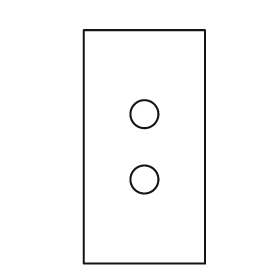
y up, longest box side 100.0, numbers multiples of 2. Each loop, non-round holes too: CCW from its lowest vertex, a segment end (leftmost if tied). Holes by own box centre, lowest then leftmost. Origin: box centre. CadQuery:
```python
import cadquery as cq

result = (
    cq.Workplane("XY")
    .moveTo(-26.0, -50.0)
    .lineTo(26.0, -50.0)
    .lineTo(26.0, 50.0)
    .lineTo(-26.0, 50.0)
    .close()
    .moveTo(0.0, -14.0)
    .circle(6.0)
    .moveTo(0.0, 14.0)
    .circle(6.0)
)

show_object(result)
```